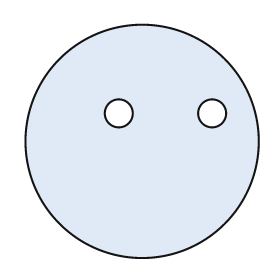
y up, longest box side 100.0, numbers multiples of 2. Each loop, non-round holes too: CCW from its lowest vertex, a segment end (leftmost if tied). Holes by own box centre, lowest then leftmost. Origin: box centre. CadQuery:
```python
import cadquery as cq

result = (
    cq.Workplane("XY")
    .moveTo(0.0, 0.0)
    .circle(50.0)
    .moveTo(-10.0, 12.0)
    .circle(6.0)
    .moveTo(30.0, 12.0)
    .circle(6.0)
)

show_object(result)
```